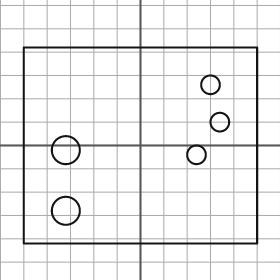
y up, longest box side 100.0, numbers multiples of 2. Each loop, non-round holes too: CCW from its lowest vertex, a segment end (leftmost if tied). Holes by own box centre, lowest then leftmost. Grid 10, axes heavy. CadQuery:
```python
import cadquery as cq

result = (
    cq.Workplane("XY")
    .moveTo(-50.0, -42.0)
    .lineTo(50.0, -42.0)
    .lineTo(50.0, 42.0)
    .lineTo(-50.0, 42.0)
    .close()
    .moveTo(-32.0, -28.0)
    .circle(6.0)
    .moveTo(24.0, -4.0)
    .circle(4.0)
    .moveTo(-32.0, -2.0)
    .circle(6.0)
    .moveTo(34.0, 10.0)
    .circle(4.0)
    .moveTo(30.0, 26.0)
    .circle(4.0)
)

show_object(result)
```